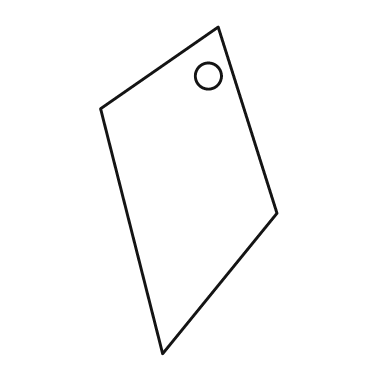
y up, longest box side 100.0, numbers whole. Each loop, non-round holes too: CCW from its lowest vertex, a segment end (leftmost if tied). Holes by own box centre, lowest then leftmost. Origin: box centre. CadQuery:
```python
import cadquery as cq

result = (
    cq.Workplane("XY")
    .moveTo(-8.0, -50.0)
    .lineTo(27.0, -7.0)
    .lineTo(9.0, 50.0)
    .lineTo(-27.0, 25.0)
    .close()
    .moveTo(6.0, 35.0)
    .circle(4.0)
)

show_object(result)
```